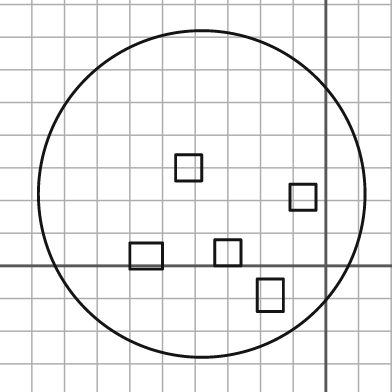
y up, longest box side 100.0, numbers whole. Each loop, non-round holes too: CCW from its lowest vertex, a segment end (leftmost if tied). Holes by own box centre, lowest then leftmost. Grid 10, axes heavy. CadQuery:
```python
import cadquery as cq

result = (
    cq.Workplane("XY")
    .moveTo(-38.0, 22.0)
    .circle(50.0)
    .moveTo(-21.0, -14.0)
    .lineTo(-13.0, -14.0)
    .lineTo(-13.0, -4.0)
    .lineTo(-21.0, -4.0)
    .close()
    .moveTo(-60.0, -1.0)
    .lineTo(-50.0, -1.0)
    .lineTo(-50.0, 7.0)
    .lineTo(-60.0, 7.0)
    .close()
    .moveTo(-34.0, 0.0)
    .lineTo(-26.0, 0.0)
    .lineTo(-26.0, 8.0)
    .lineTo(-34.0, 8.0)
    .close()
    .moveTo(-11.0, 17.0)
    .lineTo(-3.0, 17.0)
    .lineTo(-3.0, 25.0)
    .lineTo(-11.0, 25.0)
    .close()
    .moveTo(-46.0, 26.0)
    .lineTo(-38.0, 26.0)
    .lineTo(-38.0, 34.0)
    .lineTo(-46.0, 34.0)
    .close()
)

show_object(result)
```